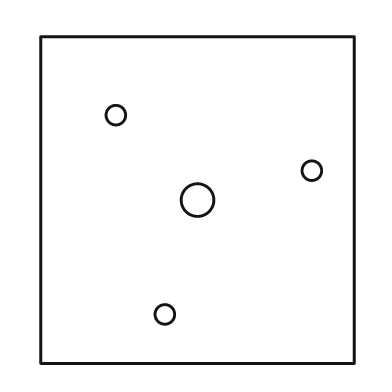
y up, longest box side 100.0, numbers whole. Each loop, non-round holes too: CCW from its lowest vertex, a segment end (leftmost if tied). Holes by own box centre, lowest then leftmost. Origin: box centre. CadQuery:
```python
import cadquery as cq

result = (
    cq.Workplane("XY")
    .moveTo(-48.0, -50.0)
    .lineTo(48.0, -50.0)
    .lineTo(48.0, 50.0)
    .lineTo(-48.0, 50.0)
    .close()
    .moveTo(-10.0, -35.0)
    .circle(3.0)
    .moveTo(0.0, 0.0)
    .circle(5.0)
    .moveTo(35.0, 9.0)
    .circle(3.0)
    .moveTo(-25.0, 26.0)
    .circle(3.0)
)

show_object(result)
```